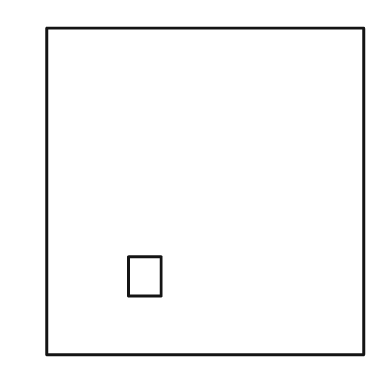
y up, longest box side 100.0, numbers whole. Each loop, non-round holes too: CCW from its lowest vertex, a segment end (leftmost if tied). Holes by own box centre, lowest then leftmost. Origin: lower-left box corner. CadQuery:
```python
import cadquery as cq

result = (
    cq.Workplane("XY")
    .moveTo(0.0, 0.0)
    .lineTo(97.0, 0.0)
    .lineTo(97.0, 100.0)
    .lineTo(0.0, 100.0)
    .close()
    .moveTo(25.0, 18.0)
    .lineTo(35.0, 18.0)
    .lineTo(35.0, 30.0)
    .lineTo(25.0, 30.0)
    .close()
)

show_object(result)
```